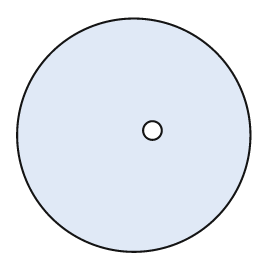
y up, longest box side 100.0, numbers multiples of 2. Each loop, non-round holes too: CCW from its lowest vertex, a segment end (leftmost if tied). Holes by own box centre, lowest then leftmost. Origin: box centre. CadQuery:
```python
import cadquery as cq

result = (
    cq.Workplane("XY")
    .moveTo(0.0, 0.0)
    .circle(50.0)
    .moveTo(8.0, 2.0)
    .circle(4.0)
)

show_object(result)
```